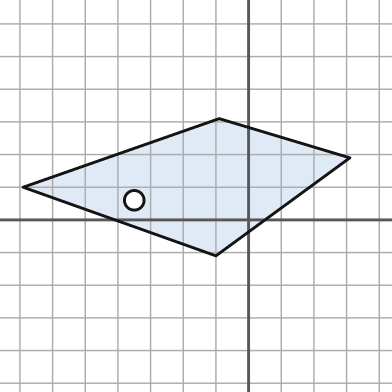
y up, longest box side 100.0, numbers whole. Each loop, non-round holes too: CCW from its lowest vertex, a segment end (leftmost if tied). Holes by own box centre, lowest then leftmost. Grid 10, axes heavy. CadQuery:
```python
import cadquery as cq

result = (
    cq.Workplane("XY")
    .moveTo(-10.0, -11.0)
    .lineTo(31.0, 19.0)
    .lineTo(-9.0, 31.0)
    .lineTo(-69.0, 10.0)
    .close()
    .moveTo(-35.0, 6.0)
    .circle(3.0)
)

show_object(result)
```